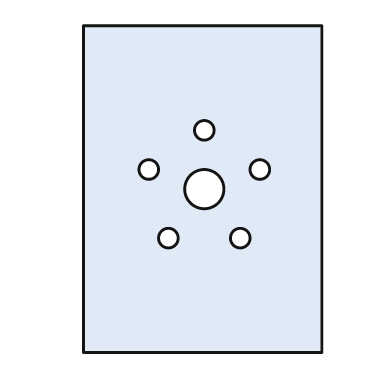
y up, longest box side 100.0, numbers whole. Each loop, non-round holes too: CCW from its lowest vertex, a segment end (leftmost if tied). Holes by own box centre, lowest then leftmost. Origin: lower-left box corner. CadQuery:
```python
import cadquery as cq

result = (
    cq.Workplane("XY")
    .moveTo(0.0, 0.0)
    .lineTo(73.0, 0.0)
    .lineTo(73.0, 100.0)
    .lineTo(0.0, 100.0)
    .close()
    .moveTo(26.0, 35.0)
    .circle(3.0)
    .moveTo(48.0, 35.0)
    .circle(3.0)
    .moveTo(37.0, 50.0)
    .circle(6.0)
    .moveTo(20.0, 56.0)
    .circle(3.0)
    .moveTo(54.0, 56.0)
    .circle(3.0)
    .moveTo(37.0, 68.0)
    .circle(3.0)
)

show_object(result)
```